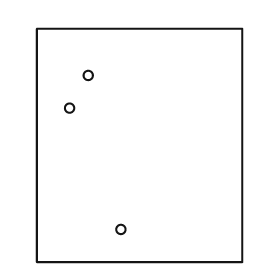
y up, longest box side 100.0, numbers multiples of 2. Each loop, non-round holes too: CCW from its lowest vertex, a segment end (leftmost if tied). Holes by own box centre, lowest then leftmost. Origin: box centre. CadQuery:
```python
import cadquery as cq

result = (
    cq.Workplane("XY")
    .moveTo(-44.0, -50.0)
    .lineTo(44.0, -50.0)
    .lineTo(44.0, 50.0)
    .lineTo(-44.0, 50.0)
    .close()
    .moveTo(-8.0, -36.0)
    .circle(2.0)
    .moveTo(-30.0, 16.0)
    .circle(2.0)
    .moveTo(-22.0, 30.0)
    .circle(2.0)
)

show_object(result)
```